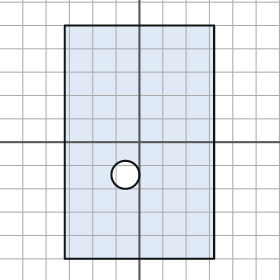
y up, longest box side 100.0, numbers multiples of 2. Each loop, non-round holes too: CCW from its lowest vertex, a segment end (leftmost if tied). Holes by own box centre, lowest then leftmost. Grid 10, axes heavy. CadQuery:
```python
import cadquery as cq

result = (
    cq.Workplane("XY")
    .moveTo(-32.0, -50.0)
    .lineTo(32.0, -50.0)
    .lineTo(32.0, 50.0)
    .lineTo(-32.0, 50.0)
    .close()
    .moveTo(-6.0, -14.0)
    .circle(6.0)
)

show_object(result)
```